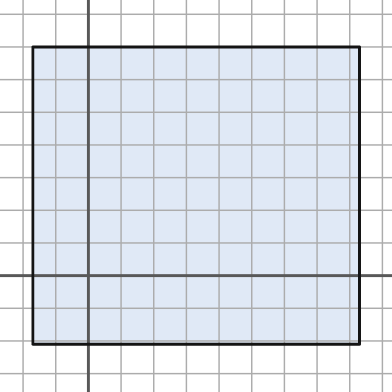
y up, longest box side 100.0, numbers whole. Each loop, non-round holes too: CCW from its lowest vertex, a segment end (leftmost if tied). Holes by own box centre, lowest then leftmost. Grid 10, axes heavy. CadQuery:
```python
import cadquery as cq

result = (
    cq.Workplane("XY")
    .moveTo(-17.0, -21.0)
    .lineTo(83.0, -21.0)
    .lineTo(83.0, 70.0)
    .lineTo(-17.0, 70.0)
    .close()
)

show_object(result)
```